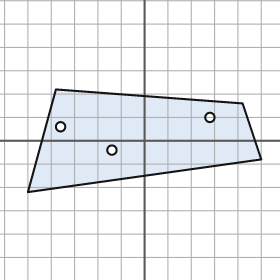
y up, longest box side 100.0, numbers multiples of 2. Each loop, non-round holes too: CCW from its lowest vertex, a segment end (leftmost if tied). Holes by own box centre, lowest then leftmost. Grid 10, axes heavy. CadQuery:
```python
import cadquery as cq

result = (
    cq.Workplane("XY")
    .moveTo(-50.0, -22.0)
    .lineTo(50.0, -8.0)
    .lineTo(42.0, 16.0)
    .lineTo(-38.0, 22.0)
    .close()
    .moveTo(-14.0, -4.0)
    .circle(2.0)
    .moveTo(-36.0, 6.0)
    .circle(2.0)
    .moveTo(28.0, 10.0)
    .circle(2.0)
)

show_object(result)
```